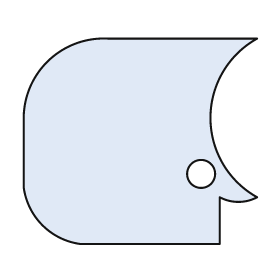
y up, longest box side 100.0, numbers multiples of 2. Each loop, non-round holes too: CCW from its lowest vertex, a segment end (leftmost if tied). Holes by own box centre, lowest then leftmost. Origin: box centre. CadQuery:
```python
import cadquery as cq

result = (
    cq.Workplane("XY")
    .moveTo(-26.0, -44.0)
    .lineTo(34.0, -44.0)
    .lineTo(34.0, -24.0)
    .threePointArc((42.0, -26.0), (50.0, -24.0))
    .threePointArc((30.0, 10.0), (50.0, 44.0))
    .lineTo(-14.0, 44.0)
    .threePointArc((-40.0, 34.0), (-50.0, 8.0))
    .lineTo(-50.0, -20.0)
    .threePointArc((-42.0, -36.0), (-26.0, -44.0))
    .close()
    .moveTo(26.0, -14.0)
    .circle(6.0)
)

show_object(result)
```